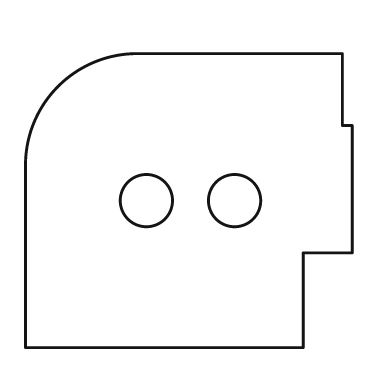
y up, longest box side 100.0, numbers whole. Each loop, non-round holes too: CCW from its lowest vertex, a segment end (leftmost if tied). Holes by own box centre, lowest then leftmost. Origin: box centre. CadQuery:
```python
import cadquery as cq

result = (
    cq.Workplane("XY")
    .moveTo(-50.0, -45.0)
    .lineTo(35.0, -45.0)
    .lineTo(35.0, -16.0)
    .lineTo(50.0, -16.0)
    .lineTo(50.0, 23.0)
    .lineTo(47.0, 23.0)
    .lineTo(47.0, 45.0)
    .lineTo(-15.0, 45.0)
    .threePointArc((-40.0, 35.0), (-50.0, 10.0))
    .close()
    .moveTo(-13.0, 0.0)
    .circle(8.0)
    .moveTo(14.0, 0.0)
    .circle(8.0)
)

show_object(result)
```